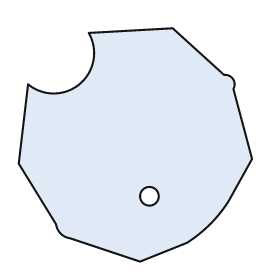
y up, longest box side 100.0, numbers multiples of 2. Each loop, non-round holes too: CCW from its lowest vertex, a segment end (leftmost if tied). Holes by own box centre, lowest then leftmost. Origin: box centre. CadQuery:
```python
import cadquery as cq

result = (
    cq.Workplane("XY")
    .moveTo(2.0, -50.0)
    .lineTo(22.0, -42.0)
    .threePointArc((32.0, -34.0), (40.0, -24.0))
    .lineTo(50.0, -6.0)
    .lineTo(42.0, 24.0)
    .threePointArc((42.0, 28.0), (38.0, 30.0))
    .lineTo(16.0, 50.0)
    .lineTo(-20.0, 48.0)
    .threePointArc((-24.0, 26.0), (-46.0, 26.0))
    .lineTo(-50.0, -8.0)
    .lineTo(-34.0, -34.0)
    .threePointArc((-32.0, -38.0), (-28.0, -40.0))
    .close()
    .moveTo(6.0, -22.0)
    .circle(4.0)
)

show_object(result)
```